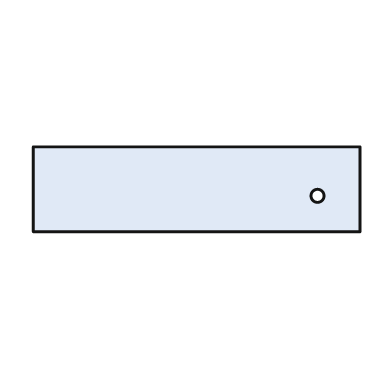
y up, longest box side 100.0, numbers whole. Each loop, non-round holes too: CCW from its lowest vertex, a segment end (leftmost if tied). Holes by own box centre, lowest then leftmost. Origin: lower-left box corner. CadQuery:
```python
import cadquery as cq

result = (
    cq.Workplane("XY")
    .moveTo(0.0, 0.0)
    .lineTo(100.0, 0.0)
    .lineTo(100.0, 26.0)
    .lineTo(0.0, 26.0)
    .close()
    .moveTo(87.0, 11.0)
    .circle(2.0)
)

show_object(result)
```